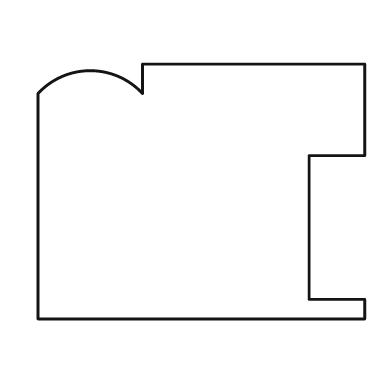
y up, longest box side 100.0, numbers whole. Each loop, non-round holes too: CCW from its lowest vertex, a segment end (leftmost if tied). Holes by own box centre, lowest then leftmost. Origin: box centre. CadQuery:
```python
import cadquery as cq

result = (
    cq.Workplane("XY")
    .moveTo(-50.0, -39.0)
    .lineTo(50.0, -39.0)
    .lineTo(50.0, -33.0)
    .lineTo(33.0, -33.0)
    .lineTo(33.0, 11.0)
    .lineTo(50.0, 11.0)
    .lineTo(50.0, 39.0)
    .lineTo(-18.0, 39.0)
    .lineTo(-18.0, 30.0)
    .threePointArc((-34.0, 37.0), (-50.0, 30.0))
    .close()
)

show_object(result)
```